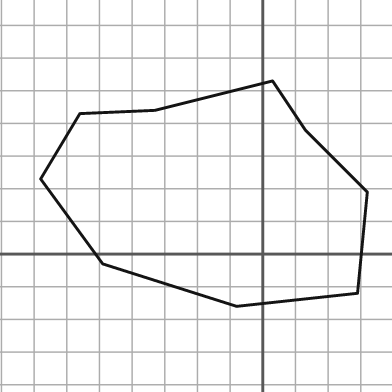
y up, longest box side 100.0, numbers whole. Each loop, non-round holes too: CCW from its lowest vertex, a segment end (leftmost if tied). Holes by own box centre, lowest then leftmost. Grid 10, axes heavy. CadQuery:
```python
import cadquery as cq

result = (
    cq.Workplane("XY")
    .moveTo(-8.0, -16.0)
    .lineTo(29.0, -12.0)
    .lineTo(32.0, 19.0)
    .lineTo(13.0, 38.0)
    .lineTo(3.0, 53.0)
    .lineTo(-33.0, 44.0)
    .lineTo(-56.0, 43.0)
    .lineTo(-68.0, 23.0)
    .lineTo(-49.0, -3.0)
    .close()
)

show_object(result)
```